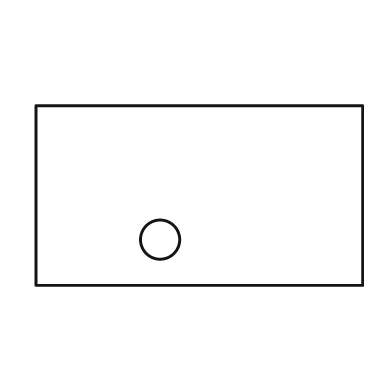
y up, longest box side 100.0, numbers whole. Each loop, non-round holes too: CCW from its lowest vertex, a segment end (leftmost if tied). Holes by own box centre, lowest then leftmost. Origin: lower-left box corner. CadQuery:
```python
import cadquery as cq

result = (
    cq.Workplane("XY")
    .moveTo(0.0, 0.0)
    .lineTo(100.0, 0.0)
    .lineTo(100.0, 55.0)
    .lineTo(0.0, 55.0)
    .close()
    .moveTo(38.0, 14.0)
    .circle(6.0)
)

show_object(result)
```